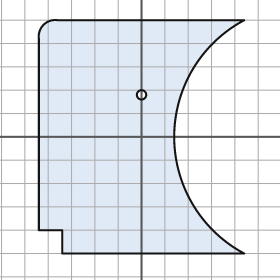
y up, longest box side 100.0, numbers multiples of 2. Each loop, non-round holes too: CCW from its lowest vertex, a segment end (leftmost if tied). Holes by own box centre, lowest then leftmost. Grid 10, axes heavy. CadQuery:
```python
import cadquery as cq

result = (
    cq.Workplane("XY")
    .moveTo(-34.0, -50.0)
    .lineTo(44.0, -50.0)
    .threePointArc((14.0, 0.0), (44.0, 50.0))
    .lineTo(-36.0, 50.0)
    .threePointArc((-42.0, 48.0), (-44.0, 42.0))
    .lineTo(-44.0, -40.0)
    .lineTo(-34.0, -40.0)
    .close()
    .moveTo(0.0, 18.0)
    .circle(2.0)
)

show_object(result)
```